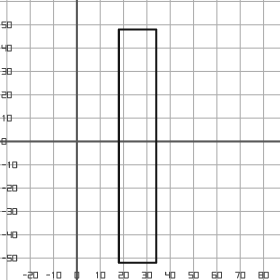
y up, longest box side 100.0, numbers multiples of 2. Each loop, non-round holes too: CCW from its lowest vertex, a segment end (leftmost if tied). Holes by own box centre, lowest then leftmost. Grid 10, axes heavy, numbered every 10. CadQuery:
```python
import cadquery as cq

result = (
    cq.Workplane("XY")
    .moveTo(18.0, -52.0)
    .lineTo(34.0, -52.0)
    .lineTo(34.0, 48.0)
    .lineTo(18.0, 48.0)
    .close()
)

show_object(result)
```